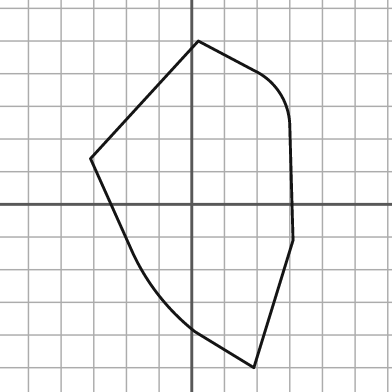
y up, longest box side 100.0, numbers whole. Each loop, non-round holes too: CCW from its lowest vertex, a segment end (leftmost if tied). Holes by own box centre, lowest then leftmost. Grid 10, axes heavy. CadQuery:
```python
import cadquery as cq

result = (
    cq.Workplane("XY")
    .moveTo(19.0, -50.0)
    .lineTo(31.0, -11.0)
    .lineTo(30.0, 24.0)
    .threePointArc((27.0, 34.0), (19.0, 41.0))
    .lineTo(2.0, 50.0)
    .lineTo(-31.0, 14.0)
    .lineTo(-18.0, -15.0)
    .threePointArc((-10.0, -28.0), (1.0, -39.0))
    .close()
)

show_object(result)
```